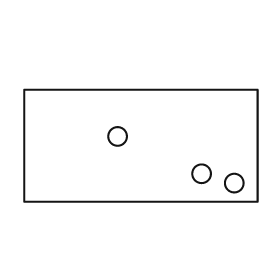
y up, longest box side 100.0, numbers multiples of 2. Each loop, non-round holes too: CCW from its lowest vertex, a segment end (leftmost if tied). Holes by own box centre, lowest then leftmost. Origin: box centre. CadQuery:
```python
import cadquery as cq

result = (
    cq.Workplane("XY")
    .moveTo(-50.0, -24.0)
    .lineTo(50.0, -24.0)
    .lineTo(50.0, 24.0)
    .lineTo(-50.0, 24.0)
    .close()
    .moveTo(40.0, -16.0)
    .circle(4.0)
    .moveTo(26.0, -12.0)
    .circle(4.0)
    .moveTo(-10.0, 4.0)
    .circle(4.0)
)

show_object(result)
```